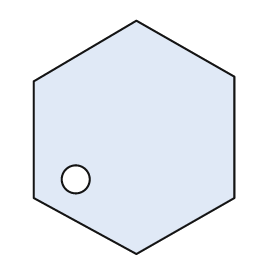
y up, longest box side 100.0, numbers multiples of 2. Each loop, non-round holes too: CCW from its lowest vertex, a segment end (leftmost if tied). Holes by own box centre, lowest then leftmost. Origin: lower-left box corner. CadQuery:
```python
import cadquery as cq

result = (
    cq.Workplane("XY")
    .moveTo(44.0, 0.0)
    .lineTo(86.0, 24.0)
    .lineTo(86.0, 76.0)
    .lineTo(44.0, 100.0)
    .lineTo(0.0, 74.0)
    .lineTo(0.0, 24.0)
    .close()
    .moveTo(18.0, 32.0)
    .circle(6.0)
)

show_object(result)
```